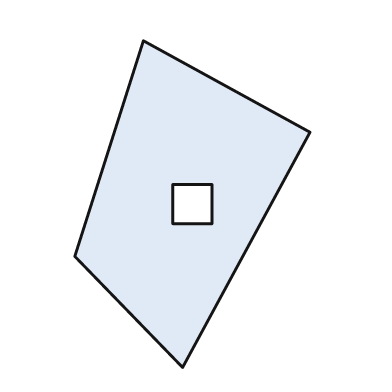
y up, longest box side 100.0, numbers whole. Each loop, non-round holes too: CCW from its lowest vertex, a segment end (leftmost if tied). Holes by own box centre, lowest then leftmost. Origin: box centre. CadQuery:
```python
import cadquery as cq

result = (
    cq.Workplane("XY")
    .moveTo(-3.0, -50.0)
    .lineTo(36.0, 22.0)
    .lineTo(-15.0, 50.0)
    .lineTo(-36.0, -16.0)
    .close()
    .moveTo(-6.0, -6.0)
    .lineTo(6.0, -6.0)
    .lineTo(6.0, 6.0)
    .lineTo(-6.0, 6.0)
    .close()
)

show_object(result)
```